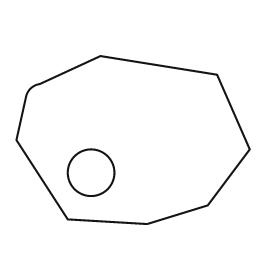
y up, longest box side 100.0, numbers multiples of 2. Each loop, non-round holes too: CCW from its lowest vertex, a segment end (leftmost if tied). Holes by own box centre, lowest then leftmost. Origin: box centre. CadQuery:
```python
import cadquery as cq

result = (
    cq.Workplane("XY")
    .moveTo(6.0, -36.0)
    .lineTo(32.0, -28.0)
    .lineTo(50.0, -4.0)
    .lineTo(36.0, 28.0)
    .lineTo(-14.0, 36.0)
    .lineTo(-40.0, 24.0)
    .threePointArc((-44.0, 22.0), (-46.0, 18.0))
    .lineTo(-50.0, 0.0)
    .lineTo(-28.0, -34.0)
    .close()
    .moveTo(-18.0, -14.0)
    .circle(10.0)
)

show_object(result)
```